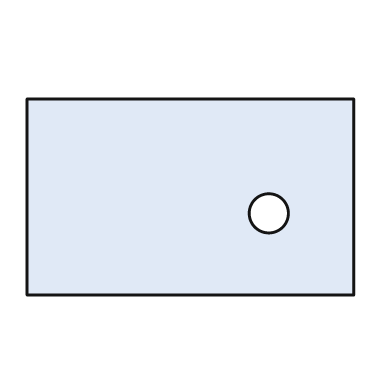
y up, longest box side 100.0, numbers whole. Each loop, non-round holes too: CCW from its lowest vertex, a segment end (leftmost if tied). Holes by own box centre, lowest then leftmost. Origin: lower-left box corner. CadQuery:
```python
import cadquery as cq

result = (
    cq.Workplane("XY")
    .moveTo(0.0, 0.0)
    .lineTo(100.0, 0.0)
    .lineTo(100.0, 60.0)
    .lineTo(0.0, 60.0)
    .close()
    .moveTo(74.0, 25.0)
    .circle(6.0)
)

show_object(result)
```